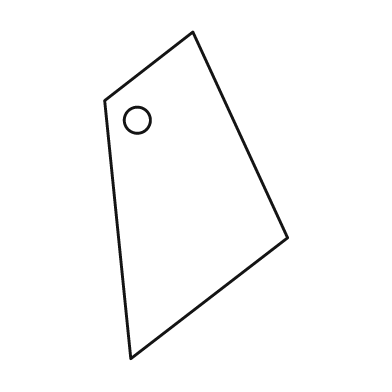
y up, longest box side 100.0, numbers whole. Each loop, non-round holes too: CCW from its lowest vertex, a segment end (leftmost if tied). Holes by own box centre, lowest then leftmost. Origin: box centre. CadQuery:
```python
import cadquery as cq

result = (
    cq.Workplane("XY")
    .moveTo(-20.0, -50.0)
    .lineTo(28.0, -13.0)
    .lineTo(-1.0, 50.0)
    .lineTo(-28.0, 29.0)
    .close()
    .moveTo(-18.0, 23.0)
    .circle(4.0)
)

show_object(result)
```